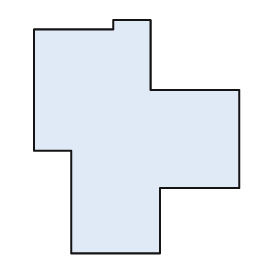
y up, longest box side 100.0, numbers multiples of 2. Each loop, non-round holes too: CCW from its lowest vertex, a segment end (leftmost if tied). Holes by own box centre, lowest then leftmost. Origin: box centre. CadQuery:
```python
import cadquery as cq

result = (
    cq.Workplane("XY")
    .moveTo(-28.0, -50.0)
    .lineTo(10.0, -50.0)
    .lineTo(10.0, -22.0)
    .lineTo(44.0, -22.0)
    .lineTo(44.0, 20.0)
    .lineTo(6.0, 20.0)
    .lineTo(6.0, 50.0)
    .lineTo(-10.0, 50.0)
    .lineTo(-10.0, 46.0)
    .lineTo(-44.0, 46.0)
    .lineTo(-44.0, -6.0)
    .lineTo(-28.0, -6.0)
    .close()
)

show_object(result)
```